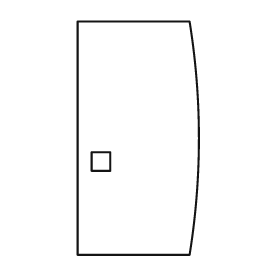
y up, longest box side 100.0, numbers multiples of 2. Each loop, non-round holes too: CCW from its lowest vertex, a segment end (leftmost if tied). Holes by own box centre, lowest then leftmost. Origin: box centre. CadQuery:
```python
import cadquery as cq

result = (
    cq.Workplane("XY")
    .moveTo(-26.0, -50.0)
    .lineTo(22.0, -50.0)
    .threePointArc((26.0, 0.0), (22.0, 50.0))
    .lineTo(-26.0, 50.0)
    .close()
    .moveTo(-20.0, -14.0)
    .lineTo(-12.0, -14.0)
    .lineTo(-12.0, -6.0)
    .lineTo(-20.0, -6.0)
    .close()
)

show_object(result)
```